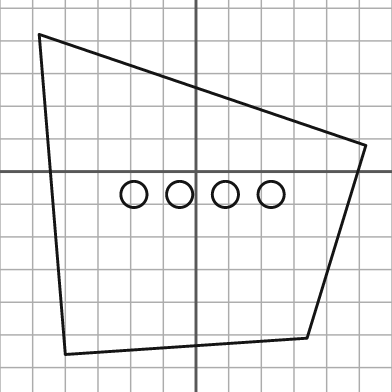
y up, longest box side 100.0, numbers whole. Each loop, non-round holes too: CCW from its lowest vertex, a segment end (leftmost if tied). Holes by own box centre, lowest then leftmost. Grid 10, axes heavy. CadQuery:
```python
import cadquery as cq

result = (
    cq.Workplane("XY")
    .moveTo(-40.0, -56.0)
    .lineTo(34.0, -51.0)
    .lineTo(52.0, 8.0)
    .lineTo(-48.0, 42.0)
    .close()
    .moveTo(-19.0, -7.0)
    .circle(4.0)
    .moveTo(-5.0, -7.0)
    .circle(4.0)
    .moveTo(9.0, -7.0)
    .circle(4.0)
    .moveTo(23.0, -7.0)
    .circle(4.0)
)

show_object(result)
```